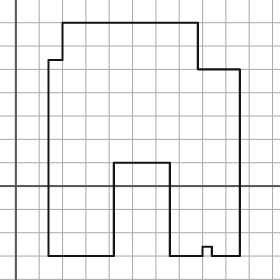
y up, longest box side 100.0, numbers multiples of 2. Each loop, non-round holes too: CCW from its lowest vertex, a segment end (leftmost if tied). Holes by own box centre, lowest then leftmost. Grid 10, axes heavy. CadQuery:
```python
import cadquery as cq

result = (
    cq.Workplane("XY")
    .moveTo(14.0, -30.0)
    .lineTo(42.0, -30.0)
    .lineTo(42.0, 10.0)
    .lineTo(66.0, 10.0)
    .lineTo(66.0, -30.0)
    .lineTo(80.0, -30.0)
    .lineTo(80.0, -26.0)
    .lineTo(84.0, -26.0)
    .lineTo(84.0, -30.0)
    .lineTo(96.0, -30.0)
    .lineTo(96.0, 50.0)
    .lineTo(78.0, 50.0)
    .lineTo(78.0, 70.0)
    .lineTo(20.0, 70.0)
    .lineTo(20.0, 54.0)
    .lineTo(14.0, 54.0)
    .close()
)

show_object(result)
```